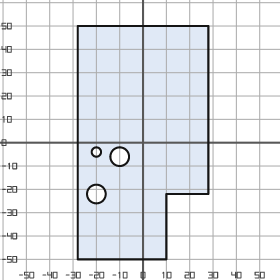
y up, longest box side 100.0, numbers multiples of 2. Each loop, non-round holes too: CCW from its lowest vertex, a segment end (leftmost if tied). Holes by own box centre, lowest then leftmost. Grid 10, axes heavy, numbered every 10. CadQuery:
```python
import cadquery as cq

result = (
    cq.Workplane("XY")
    .moveTo(-28.0, -50.0)
    .lineTo(10.0, -50.0)
    .lineTo(10.0, -22.0)
    .lineTo(28.0, -22.0)
    .lineTo(28.0, 50.0)
    .lineTo(-28.0, 50.0)
    .close()
    .moveTo(-20.0, -22.0)
    .circle(4.0)
    .moveTo(-10.0, -6.0)
    .circle(4.0)
    .moveTo(-20.0, -4.0)
    .circle(2.0)
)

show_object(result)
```